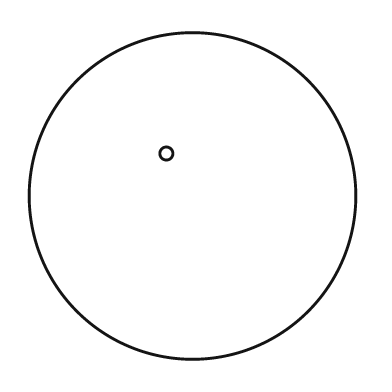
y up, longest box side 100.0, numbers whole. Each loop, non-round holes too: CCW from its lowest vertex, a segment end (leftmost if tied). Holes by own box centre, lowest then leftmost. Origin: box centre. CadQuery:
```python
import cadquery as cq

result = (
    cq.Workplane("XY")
    .moveTo(0.0, 0.0)
    .circle(50.0)
    .moveTo(-8.0, 13.0)
    .circle(2.0)
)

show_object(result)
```